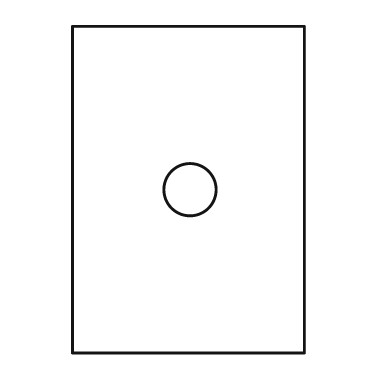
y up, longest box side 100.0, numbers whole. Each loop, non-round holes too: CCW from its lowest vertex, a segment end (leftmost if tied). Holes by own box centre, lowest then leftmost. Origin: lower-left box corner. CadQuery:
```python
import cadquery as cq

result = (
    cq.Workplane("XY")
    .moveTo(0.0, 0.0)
    .lineTo(71.0, 0.0)
    .lineTo(71.0, 100.0)
    .lineTo(0.0, 100.0)
    .close()
    .moveTo(36.0, 50.0)
    .circle(8.0)
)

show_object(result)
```